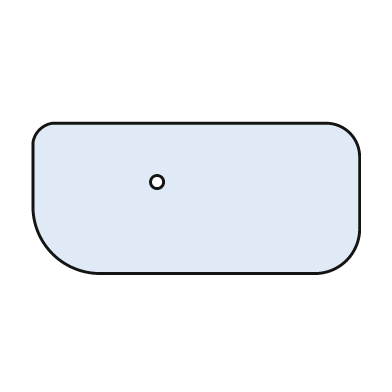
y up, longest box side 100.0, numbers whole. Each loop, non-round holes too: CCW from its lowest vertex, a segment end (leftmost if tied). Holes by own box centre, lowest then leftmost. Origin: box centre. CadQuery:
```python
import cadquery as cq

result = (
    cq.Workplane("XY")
    .moveTo(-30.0, -23.0)
    .lineTo(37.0, -23.0)
    .threePointArc((46.0, -19.0), (50.0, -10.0))
    .lineTo(50.0, 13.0)
    .threePointArc((47.0, 20.0), (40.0, 23.0))
    .lineTo(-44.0, 23.0)
    .threePointArc((-48.0, 21.0), (-50.0, 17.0))
    .lineTo(-50.0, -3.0)
    .threePointArc((-44.0, -17.0), (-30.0, -23.0))
    .close()
    .moveTo(-12.0, 5.0)
    .circle(2.0)
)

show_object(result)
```